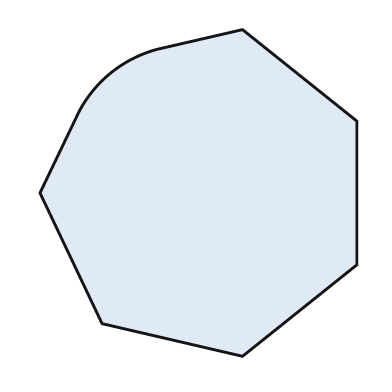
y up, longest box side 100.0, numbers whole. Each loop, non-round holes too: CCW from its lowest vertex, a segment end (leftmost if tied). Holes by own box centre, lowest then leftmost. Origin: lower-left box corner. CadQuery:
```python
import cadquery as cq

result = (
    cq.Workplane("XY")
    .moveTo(62.0, 0.0)
    .lineTo(97.0, 28.0)
    .lineTo(97.0, 72.0)
    .lineTo(62.0, 100.0)
    .lineTo(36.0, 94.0)
    .threePointArc((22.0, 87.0), (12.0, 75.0))
    .lineTo(0.0, 50.0)
    .lineTo(19.0, 10.0)
    .close()
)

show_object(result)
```